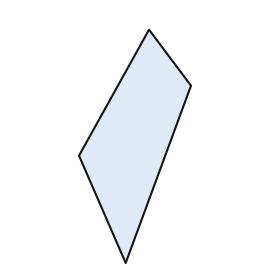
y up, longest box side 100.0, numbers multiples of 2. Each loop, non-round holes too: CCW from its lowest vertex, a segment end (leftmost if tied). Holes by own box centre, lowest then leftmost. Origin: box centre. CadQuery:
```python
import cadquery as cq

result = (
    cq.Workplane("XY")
    .moveTo(-4.0, -50.0)
    .lineTo(24.0, 26.0)
    .lineTo(6.0, 50.0)
    .lineTo(-24.0, -4.0)
    .close()
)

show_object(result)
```